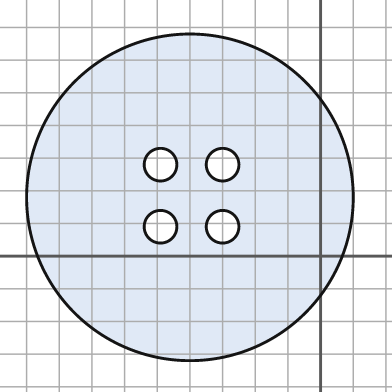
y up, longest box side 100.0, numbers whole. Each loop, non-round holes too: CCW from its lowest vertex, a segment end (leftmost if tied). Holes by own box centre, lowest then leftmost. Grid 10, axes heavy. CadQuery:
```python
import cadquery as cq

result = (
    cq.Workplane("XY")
    .moveTo(-40.0, 18.0)
    .circle(50.0)
    .moveTo(-49.0, 9.0)
    .circle(5.0)
    .moveTo(-30.0, 9.0)
    .circle(5.0)
    .moveTo(-49.0, 28.0)
    .circle(5.0)
    .moveTo(-30.0, 28.0)
    .circle(5.0)
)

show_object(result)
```